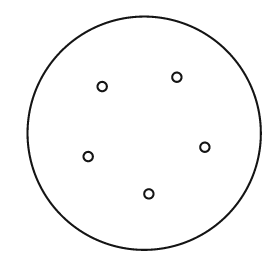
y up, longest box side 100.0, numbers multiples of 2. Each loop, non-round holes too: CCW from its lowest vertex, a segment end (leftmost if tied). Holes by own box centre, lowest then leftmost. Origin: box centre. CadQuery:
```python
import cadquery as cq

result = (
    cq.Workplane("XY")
    .moveTo(0.0, 0.0)
    .circle(50.0)
    .moveTo(2.0, -26.0)
    .circle(2.0)
    .moveTo(-24.0, -10.0)
    .circle(2.0)
    .moveTo(26.0, -6.0)
    .circle(2.0)
    .moveTo(-18.0, 20.0)
    .circle(2.0)
    .moveTo(14.0, 24.0)
    .circle(2.0)
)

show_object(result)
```